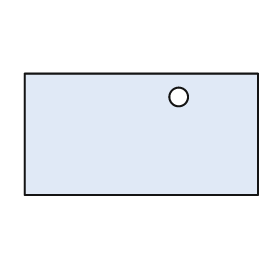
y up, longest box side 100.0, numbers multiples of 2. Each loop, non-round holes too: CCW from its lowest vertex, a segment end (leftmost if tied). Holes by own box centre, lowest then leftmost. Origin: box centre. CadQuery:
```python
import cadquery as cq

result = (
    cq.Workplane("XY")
    .moveTo(-50.0, -26.0)
    .lineTo(50.0, -26.0)
    .lineTo(50.0, 26.0)
    .lineTo(-50.0, 26.0)
    .close()
    .moveTo(16.0, 16.0)
    .circle(4.0)
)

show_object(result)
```